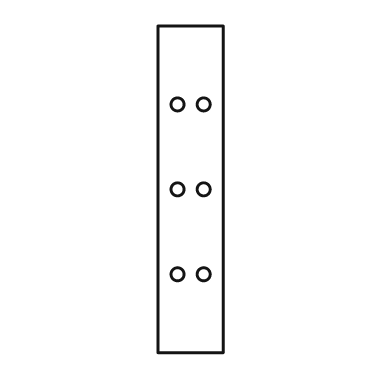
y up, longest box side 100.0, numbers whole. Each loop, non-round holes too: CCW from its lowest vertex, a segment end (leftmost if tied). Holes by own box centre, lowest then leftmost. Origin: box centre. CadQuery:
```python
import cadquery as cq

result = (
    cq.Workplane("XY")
    .moveTo(-10.0, -50.0)
    .lineTo(10.0, -50.0)
    .lineTo(10.0, 50.0)
    .lineTo(-10.0, 50.0)
    .close()
    .moveTo(-4.0, -26.0)
    .circle(2.0)
    .moveTo(4.0, -26.0)
    .circle(2.0)
    .moveTo(-4.0, 0.0)
    .circle(2.0)
    .moveTo(4.0, 0.0)
    .circle(2.0)
    .moveTo(-4.0, 26.0)
    .circle(2.0)
    .moveTo(4.0, 26.0)
    .circle(2.0)
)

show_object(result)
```